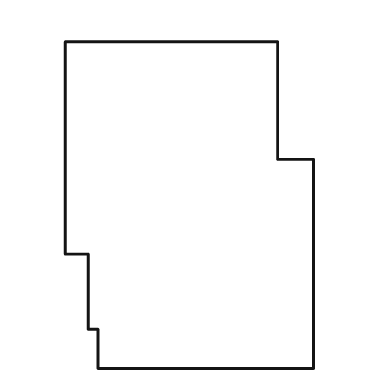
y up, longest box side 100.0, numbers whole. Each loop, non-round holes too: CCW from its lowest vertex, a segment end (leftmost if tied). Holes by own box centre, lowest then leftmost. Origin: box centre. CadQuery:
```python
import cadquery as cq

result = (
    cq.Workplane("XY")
    .moveTo(-28.0, -50.0)
    .lineTo(38.0, -50.0)
    .lineTo(38.0, 14.0)
    .lineTo(27.0, 14.0)
    .lineTo(27.0, 50.0)
    .lineTo(-38.0, 50.0)
    .lineTo(-38.0, -15.0)
    .lineTo(-31.0, -15.0)
    .lineTo(-31.0, -38.0)
    .lineTo(-28.0, -38.0)
    .close()
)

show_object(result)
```